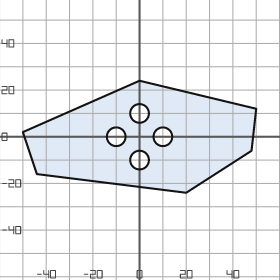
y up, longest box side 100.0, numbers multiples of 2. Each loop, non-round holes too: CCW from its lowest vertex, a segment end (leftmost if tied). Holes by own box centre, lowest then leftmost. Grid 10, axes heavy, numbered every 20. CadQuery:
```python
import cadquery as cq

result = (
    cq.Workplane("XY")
    .moveTo(20.0, -24.0)
    .lineTo(48.0, -6.0)
    .lineTo(50.0, 12.0)
    .lineTo(0.0, 24.0)
    .lineTo(-50.0, 2.0)
    .lineTo(-44.0, -16.0)
    .close()
    .moveTo(0.0, -10.0)
    .circle(4.0)
    .moveTo(-10.0, 0.0)
    .circle(4.0)
    .moveTo(10.0, 0.0)
    .circle(4.0)
    .moveTo(0.0, 10.0)
    .circle(4.0)
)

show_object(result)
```